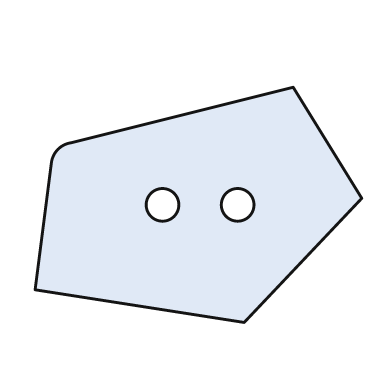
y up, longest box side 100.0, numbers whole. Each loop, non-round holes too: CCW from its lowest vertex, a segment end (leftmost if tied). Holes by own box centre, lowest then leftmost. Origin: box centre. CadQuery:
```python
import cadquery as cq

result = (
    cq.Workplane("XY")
    .moveTo(14.0, -36.0)
    .lineTo(50.0, 2.0)
    .lineTo(29.0, 36.0)
    .lineTo(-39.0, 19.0)
    .threePointArc((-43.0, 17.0), (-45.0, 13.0))
    .lineTo(-50.0, -26.0)
    .close()
    .moveTo(-11.0, 0.0)
    .circle(5.0)
    .moveTo(12.0, 0.0)
    .circle(5.0)
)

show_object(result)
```